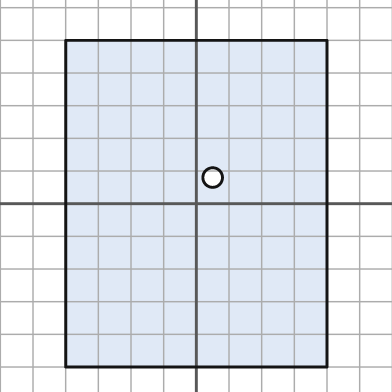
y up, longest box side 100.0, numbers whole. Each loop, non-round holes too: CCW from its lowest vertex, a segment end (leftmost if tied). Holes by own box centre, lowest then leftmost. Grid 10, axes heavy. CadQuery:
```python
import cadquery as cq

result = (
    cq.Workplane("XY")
    .moveTo(-40.0, -50.0)
    .lineTo(40.0, -50.0)
    .lineTo(40.0, 50.0)
    .lineTo(-40.0, 50.0)
    .close()
    .moveTo(5.0, 8.0)
    .circle(3.0)
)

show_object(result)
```